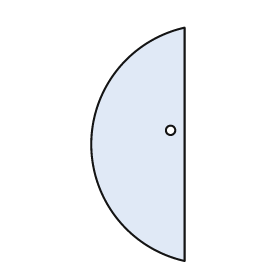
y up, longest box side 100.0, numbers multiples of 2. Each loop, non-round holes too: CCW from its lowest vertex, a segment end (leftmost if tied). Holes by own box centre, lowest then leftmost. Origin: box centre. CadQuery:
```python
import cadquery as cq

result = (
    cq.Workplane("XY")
    .moveTo(20.0, -50.0)
    .lineTo(20.0, 50.0)
    .threePointArc((-20.0, 0.0), (20.0, -50.0))
    .close()
    .moveTo(14.0, 6.0)
    .circle(2.0)
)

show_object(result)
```